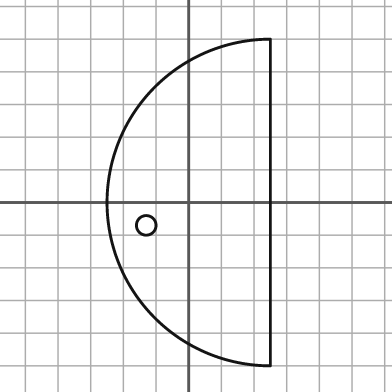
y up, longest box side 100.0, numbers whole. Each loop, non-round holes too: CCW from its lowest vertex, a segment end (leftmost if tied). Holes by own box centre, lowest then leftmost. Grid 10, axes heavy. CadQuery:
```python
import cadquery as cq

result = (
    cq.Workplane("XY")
    .moveTo(25.0, -50.0)
    .lineTo(25.0, 50.0)
    .threePointArc((-25.0, 0.0), (25.0, -50.0))
    .close()
    .moveTo(-13.0, -7.0)
    .circle(3.0)
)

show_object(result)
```